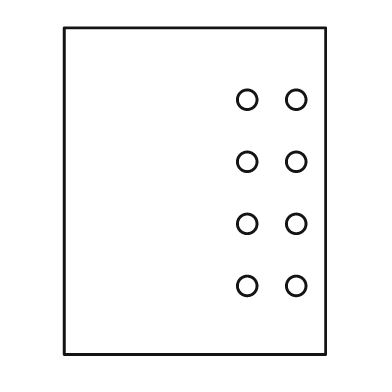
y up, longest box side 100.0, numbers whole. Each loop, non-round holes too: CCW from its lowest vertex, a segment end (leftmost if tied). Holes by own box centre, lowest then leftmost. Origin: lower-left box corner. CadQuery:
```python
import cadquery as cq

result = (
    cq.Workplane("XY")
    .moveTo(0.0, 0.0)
    .lineTo(80.0, 0.0)
    .lineTo(80.0, 100.0)
    .lineTo(0.0, 100.0)
    .close()
    .moveTo(56.0, 21.0)
    .circle(3.0)
    .moveTo(71.0, 21.0)
    .circle(3.0)
    .moveTo(56.0, 40.0)
    .circle(3.0)
    .moveTo(71.0, 40.0)
    .circle(3.0)
    .moveTo(56.0, 59.0)
    .circle(3.0)
    .moveTo(71.0, 59.0)
    .circle(3.0)
    .moveTo(56.0, 78.0)
    .circle(3.0)
    .moveTo(71.0, 78.0)
    .circle(3.0)
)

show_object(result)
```